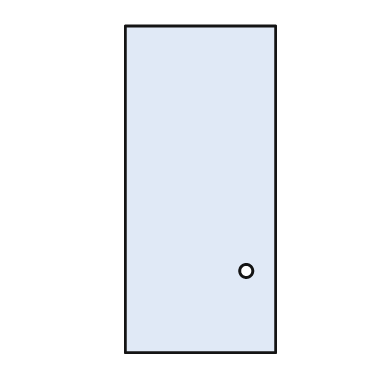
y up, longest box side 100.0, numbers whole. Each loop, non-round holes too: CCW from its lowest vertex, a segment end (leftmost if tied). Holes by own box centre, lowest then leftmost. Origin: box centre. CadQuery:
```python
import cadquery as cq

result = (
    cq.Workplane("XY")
    .moveTo(-23.0, -50.0)
    .lineTo(23.0, -50.0)
    .lineTo(23.0, 50.0)
    .lineTo(-23.0, 50.0)
    .close()
    .moveTo(14.0, -25.0)
    .circle(2.0)
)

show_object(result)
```